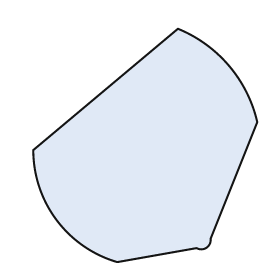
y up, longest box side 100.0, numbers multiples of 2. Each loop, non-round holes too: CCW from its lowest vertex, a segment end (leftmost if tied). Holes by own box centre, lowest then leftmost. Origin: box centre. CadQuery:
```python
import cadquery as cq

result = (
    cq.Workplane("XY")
    .moveTo(-12.0, -50.0)
    .lineTo(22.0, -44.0)
    .threePointArc((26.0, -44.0), (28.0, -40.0))
    .lineTo(48.0, 10.0)
    .threePointArc((36.0, 34.0), (14.0, 50.0))
    .lineTo(-48.0, -2.0)
    .threePointArc((-38.0, -32.0), (-12.0, -50.0))
    .close()
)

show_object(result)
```